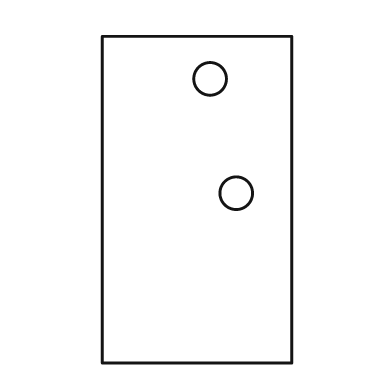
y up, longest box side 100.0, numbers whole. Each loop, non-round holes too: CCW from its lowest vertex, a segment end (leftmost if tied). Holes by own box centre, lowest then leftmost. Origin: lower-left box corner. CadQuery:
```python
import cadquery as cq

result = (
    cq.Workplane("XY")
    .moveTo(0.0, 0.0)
    .lineTo(58.0, 0.0)
    .lineTo(58.0, 100.0)
    .lineTo(0.0, 100.0)
    .close()
    .moveTo(41.0, 52.0)
    .circle(5.0)
    .moveTo(33.0, 87.0)
    .circle(5.0)
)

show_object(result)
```